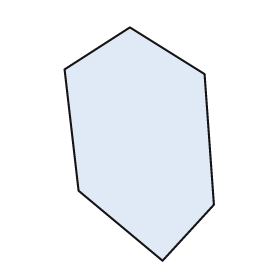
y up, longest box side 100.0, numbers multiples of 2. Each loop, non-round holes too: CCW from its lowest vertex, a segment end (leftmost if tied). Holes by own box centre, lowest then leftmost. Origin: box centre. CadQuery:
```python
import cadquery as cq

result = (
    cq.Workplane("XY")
    .moveTo(10.0, -50.0)
    .lineTo(32.0, -26.0)
    .lineTo(28.0, 30.0)
    .lineTo(-4.0, 50.0)
    .lineTo(-32.0, 32.0)
    .lineTo(-26.0, -20.0)
    .close()
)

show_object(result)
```